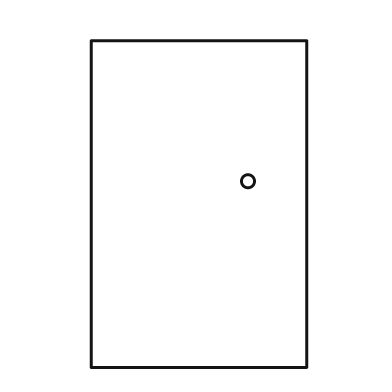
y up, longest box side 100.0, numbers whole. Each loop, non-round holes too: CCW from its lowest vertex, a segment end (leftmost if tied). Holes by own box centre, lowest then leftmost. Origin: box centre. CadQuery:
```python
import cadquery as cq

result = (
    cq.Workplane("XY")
    .moveTo(-33.0, -50.0)
    .lineTo(33.0, -50.0)
    .lineTo(33.0, 50.0)
    .lineTo(-33.0, 50.0)
    .close()
    .moveTo(15.0, 7.0)
    .circle(2.0)
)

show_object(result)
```